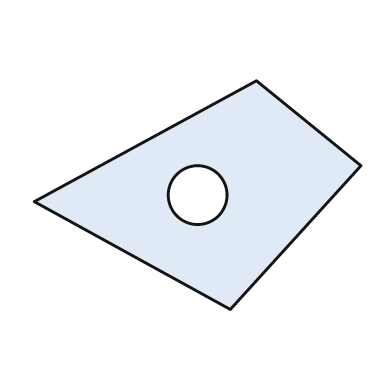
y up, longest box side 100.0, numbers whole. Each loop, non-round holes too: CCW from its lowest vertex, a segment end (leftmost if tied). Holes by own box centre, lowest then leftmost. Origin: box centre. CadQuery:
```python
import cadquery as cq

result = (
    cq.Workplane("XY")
    .moveTo(10.0, -35.0)
    .lineTo(50.0, 9.0)
    .lineTo(18.0, 35.0)
    .lineTo(-50.0, -2.0)
    .close()
    .moveTo(0.0, 0.0)
    .circle(9.0)
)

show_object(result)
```